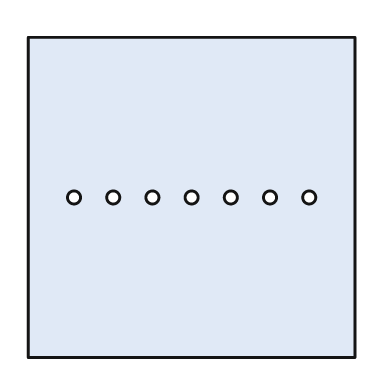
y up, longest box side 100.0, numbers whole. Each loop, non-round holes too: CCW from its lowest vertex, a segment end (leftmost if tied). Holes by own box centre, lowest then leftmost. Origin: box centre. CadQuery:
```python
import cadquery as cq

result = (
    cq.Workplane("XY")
    .moveTo(-50.0, -49.0)
    .lineTo(50.0, -49.0)
    .lineTo(50.0, 49.0)
    .lineTo(-50.0, 49.0)
    .close()
    .moveTo(-36.0, 0.0)
    .circle(2.0)
    .moveTo(-24.0, 0.0)
    .circle(2.0)
    .moveTo(-12.0, 0.0)
    .circle(2.0)
    .moveTo(0.0, 0.0)
    .circle(2.0)
    .moveTo(12.0, 0.0)
    .circle(2.0)
    .moveTo(24.0, 0.0)
    .circle(2.0)
    .moveTo(36.0, 0.0)
    .circle(2.0)
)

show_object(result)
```